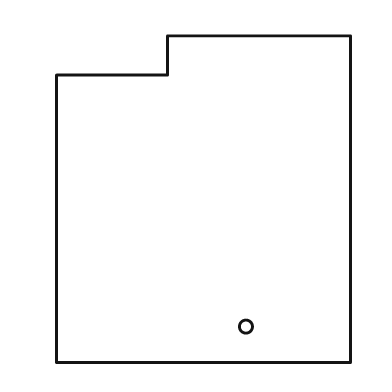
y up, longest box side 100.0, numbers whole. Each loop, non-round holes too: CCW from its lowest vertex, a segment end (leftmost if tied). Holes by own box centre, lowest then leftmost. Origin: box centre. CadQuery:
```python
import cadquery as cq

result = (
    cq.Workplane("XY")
    .moveTo(-45.0, -50.0)
    .lineTo(45.0, -50.0)
    .lineTo(45.0, 50.0)
    .lineTo(-11.0, 50.0)
    .lineTo(-11.0, 38.0)
    .lineTo(-45.0, 38.0)
    .close()
    .moveTo(13.0, -39.0)
    .circle(2.0)
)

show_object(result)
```